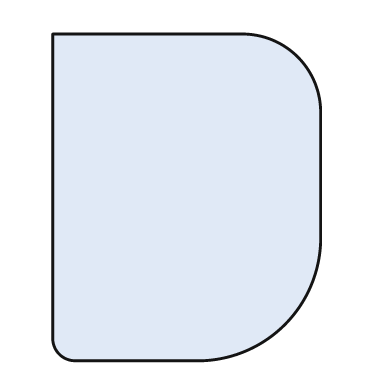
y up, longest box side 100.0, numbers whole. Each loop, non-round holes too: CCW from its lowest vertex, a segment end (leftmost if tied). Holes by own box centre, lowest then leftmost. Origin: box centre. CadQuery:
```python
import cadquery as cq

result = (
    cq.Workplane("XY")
    .moveTo(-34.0, -50.0)
    .lineTo(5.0, -50.0)
    .threePointArc((30.0, -39.0), (41.0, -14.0))
    .lineTo(41.0, 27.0)
    .threePointArc((34.0, 43.0), (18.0, 50.0))
    .lineTo(-41.0, 50.0)
    .lineTo(-41.0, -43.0)
    .threePointArc((-39.0, -48.0), (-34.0, -50.0))
    .close()
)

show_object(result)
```